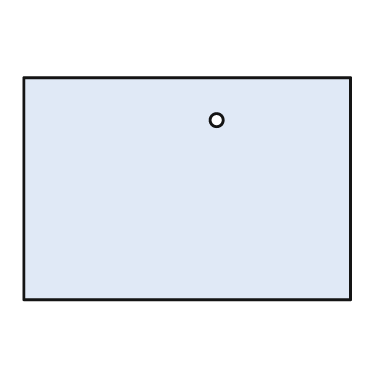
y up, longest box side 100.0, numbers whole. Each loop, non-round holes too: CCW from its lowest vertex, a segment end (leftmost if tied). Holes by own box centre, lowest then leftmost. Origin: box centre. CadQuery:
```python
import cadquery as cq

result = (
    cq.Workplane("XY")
    .moveTo(-50.0, -34.0)
    .lineTo(50.0, -34.0)
    .lineTo(50.0, 34.0)
    .lineTo(-50.0, 34.0)
    .close()
    .moveTo(9.0, 21.0)
    .circle(2.0)
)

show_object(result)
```